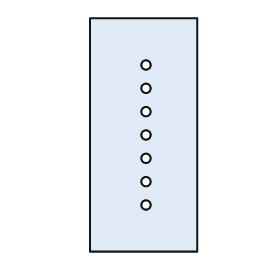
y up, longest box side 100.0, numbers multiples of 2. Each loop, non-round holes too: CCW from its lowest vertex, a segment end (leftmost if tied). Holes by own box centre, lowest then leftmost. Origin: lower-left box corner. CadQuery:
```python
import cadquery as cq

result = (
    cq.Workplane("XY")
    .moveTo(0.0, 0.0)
    .lineTo(46.0, 0.0)
    .lineTo(46.0, 100.0)
    .lineTo(0.0, 100.0)
    .close()
    .moveTo(24.0, 20.0)
    .circle(2.0)
    .moveTo(24.0, 30.0)
    .circle(2.0)
    .moveTo(24.0, 40.0)
    .circle(2.0)
    .moveTo(24.0, 50.0)
    .circle(2.0)
    .moveTo(24.0, 60.0)
    .circle(2.0)
    .moveTo(24.0, 70.0)
    .circle(2.0)
    .moveTo(24.0, 80.0)
    .circle(2.0)
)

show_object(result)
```